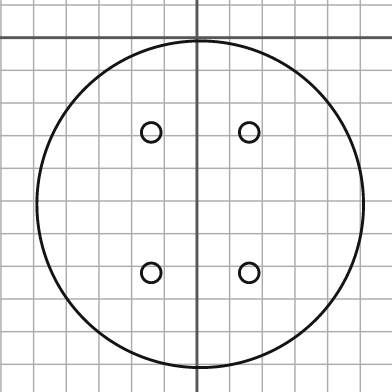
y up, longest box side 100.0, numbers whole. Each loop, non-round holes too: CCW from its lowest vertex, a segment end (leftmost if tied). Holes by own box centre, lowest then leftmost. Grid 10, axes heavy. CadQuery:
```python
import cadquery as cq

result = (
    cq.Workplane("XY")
    .moveTo(1.0, -51.0)
    .circle(50.0)
    .moveTo(-14.0, -72.0)
    .circle(3.0)
    .moveTo(16.0, -72.0)
    .circle(3.0)
    .moveTo(-14.0, -29.0)
    .circle(3.0)
    .moveTo(16.0, -29.0)
    .circle(3.0)
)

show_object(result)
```